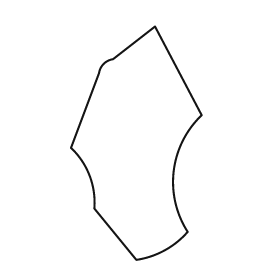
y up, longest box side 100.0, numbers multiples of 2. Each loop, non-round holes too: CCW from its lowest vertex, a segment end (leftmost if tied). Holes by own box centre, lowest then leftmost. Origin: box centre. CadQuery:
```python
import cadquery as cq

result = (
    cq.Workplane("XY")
    .moveTo(0.0, -50.0)
    .threePointArc((12.0, -46.0), (22.0, -38.0))
    .threePointArc((16.0, -12.0), (28.0, 12.0))
    .lineTo(8.0, 50.0)
    .lineTo(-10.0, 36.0)
    .threePointArc((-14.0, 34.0), (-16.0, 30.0))
    .lineTo(-28.0, -2.0)
    .threePointArc((-20.0, -14.0), (-18.0, -28.0))
    .close()
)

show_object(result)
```